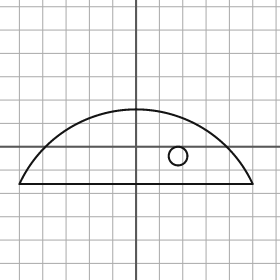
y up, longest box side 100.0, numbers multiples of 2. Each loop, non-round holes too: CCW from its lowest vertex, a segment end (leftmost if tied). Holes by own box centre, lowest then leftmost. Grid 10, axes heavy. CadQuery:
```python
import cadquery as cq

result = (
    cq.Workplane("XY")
    .moveTo(-50.0, -16.0)
    .lineTo(50.0, -16.0)
    .threePointArc((0.0, 16.0), (-50.0, -16.0))
    .close()
    .moveTo(18.0, -4.0)
    .circle(4.0)
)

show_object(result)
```